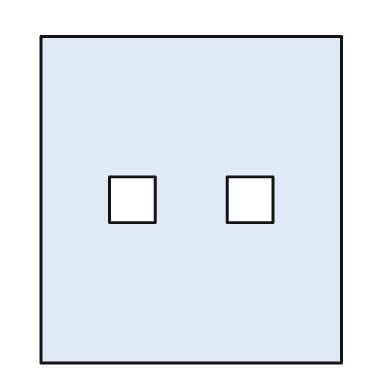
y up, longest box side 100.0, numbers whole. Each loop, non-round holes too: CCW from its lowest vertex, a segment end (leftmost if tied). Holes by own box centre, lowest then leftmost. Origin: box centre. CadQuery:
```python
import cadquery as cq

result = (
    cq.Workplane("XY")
    .moveTo(-46.0, -50.0)
    .lineTo(46.0, -50.0)
    .lineTo(46.0, 50.0)
    .lineTo(-46.0, 50.0)
    .close()
    .moveTo(-25.0, -7.0)
    .lineTo(-11.0, -7.0)
    .lineTo(-11.0, 7.0)
    .lineTo(-25.0, 7.0)
    .close()
    .moveTo(11.0, -7.0)
    .lineTo(25.0, -7.0)
    .lineTo(25.0, 7.0)
    .lineTo(11.0, 7.0)
    .close()
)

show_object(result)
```